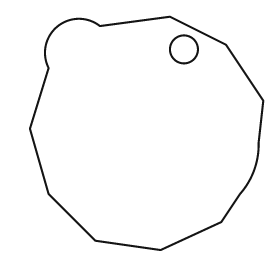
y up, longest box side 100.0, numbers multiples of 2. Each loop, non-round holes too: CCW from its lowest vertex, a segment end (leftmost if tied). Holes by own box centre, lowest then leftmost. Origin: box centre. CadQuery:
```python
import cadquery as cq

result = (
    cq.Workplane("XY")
    .moveTo(6.0, -50.0)
    .lineTo(32.0, -38.0)
    .lineTo(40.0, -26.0)
    .threePointArc((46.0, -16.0), (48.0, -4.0))
    .lineTo(50.0, 14.0)
    .lineTo(34.0, 38.0)
    .lineTo(10.0, 50.0)
    .lineTo(-20.0, 46.0)
    .threePointArc((-38.0, 46.0), (-42.0, 28.0))
    .lineTo(-50.0, 2.0)
    .lineTo(-42.0, -26.0)
    .lineTo(-22.0, -46.0)
    .close()
    .moveTo(16.0, 36.0)
    .circle(6.0)
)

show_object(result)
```